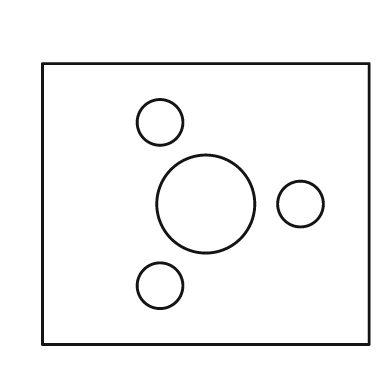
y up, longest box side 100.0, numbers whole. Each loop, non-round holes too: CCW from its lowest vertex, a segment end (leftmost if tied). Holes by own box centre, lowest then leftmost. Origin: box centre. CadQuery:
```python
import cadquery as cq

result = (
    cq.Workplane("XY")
    .moveTo(-50.0, -43.0)
    .lineTo(50.0, -43.0)
    .lineTo(50.0, 43.0)
    .lineTo(-50.0, 43.0)
    .close()
    .moveTo(-14.0, -25.0)
    .circle(7.0)
    .moveTo(0.0, 0.0)
    .circle(15.0)
    .moveTo(29.0, 0.0)
    .circle(7.0)
    .moveTo(-14.0, 25.0)
    .circle(7.0)
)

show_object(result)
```